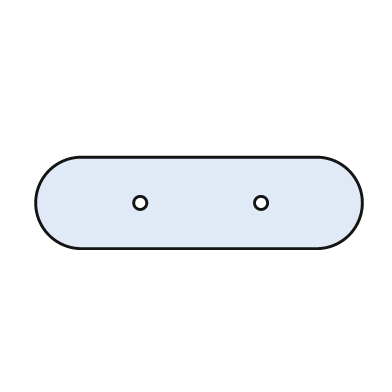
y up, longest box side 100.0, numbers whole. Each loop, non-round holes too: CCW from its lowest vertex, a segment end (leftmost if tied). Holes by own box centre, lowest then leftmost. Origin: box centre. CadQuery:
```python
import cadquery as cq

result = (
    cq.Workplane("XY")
    .moveTo(-36.0, -14.0)
    .lineTo(36.0, -14.0)
    .threePointArc((50.0, 0.0), (36.0, 14.0))
    .lineTo(-36.0, 14.0)
    .threePointArc((-50.0, 0.0), (-36.0, -14.0))
    .close()
    .moveTo(-18.0, 0.0)
    .circle(2.0)
    .moveTo(19.0, 0.0)
    .circle(2.0)
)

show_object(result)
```